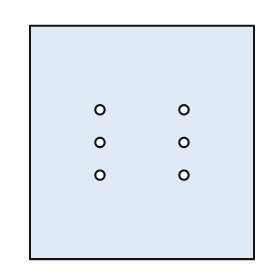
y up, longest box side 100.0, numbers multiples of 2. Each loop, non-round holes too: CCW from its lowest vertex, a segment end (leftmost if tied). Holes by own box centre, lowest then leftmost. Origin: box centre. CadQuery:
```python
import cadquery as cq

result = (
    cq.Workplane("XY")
    .moveTo(-48.0, -50.0)
    .lineTo(48.0, -50.0)
    .lineTo(48.0, 50.0)
    .lineTo(-48.0, 50.0)
    .close()
    .moveTo(-18.0, -14.0)
    .circle(2.0)
    .moveTo(18.0, -14.0)
    .circle(2.0)
    .moveTo(-18.0, 0.0)
    .circle(2.0)
    .moveTo(18.0, 0.0)
    .circle(2.0)
    .moveTo(-18.0, 14.0)
    .circle(2.0)
    .moveTo(18.0, 14.0)
    .circle(2.0)
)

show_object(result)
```